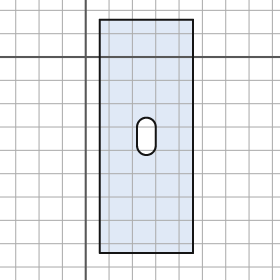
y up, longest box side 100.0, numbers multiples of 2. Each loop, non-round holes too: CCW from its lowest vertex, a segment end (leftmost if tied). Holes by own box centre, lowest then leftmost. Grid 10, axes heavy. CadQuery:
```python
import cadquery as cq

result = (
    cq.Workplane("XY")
    .moveTo(6.0, -84.0)
    .lineTo(46.0, -84.0)
    .lineTo(46.0, 16.0)
    .lineTo(6.0, 16.0)
    .close()
    .moveTo(22.0, -38.0)
    .threePointArc((26.0, -42.0), (30.0, -38.0))
    .lineTo(30.0, -30.0)
    .threePointArc((26.0, -26.0), (22.0, -30.0))
    .close()
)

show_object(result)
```